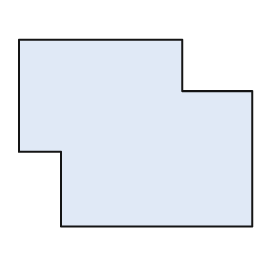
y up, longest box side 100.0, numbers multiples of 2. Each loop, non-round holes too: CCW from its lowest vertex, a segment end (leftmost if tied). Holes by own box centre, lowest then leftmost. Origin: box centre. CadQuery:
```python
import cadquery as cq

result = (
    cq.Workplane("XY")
    .moveTo(-32.0, -40.0)
    .lineTo(50.0, -40.0)
    .lineTo(50.0, 18.0)
    .lineTo(20.0, 18.0)
    .lineTo(20.0, 40.0)
    .lineTo(-50.0, 40.0)
    .lineTo(-50.0, -8.0)
    .lineTo(-32.0, -8.0)
    .close()
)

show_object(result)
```